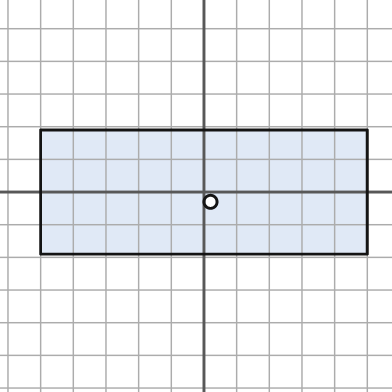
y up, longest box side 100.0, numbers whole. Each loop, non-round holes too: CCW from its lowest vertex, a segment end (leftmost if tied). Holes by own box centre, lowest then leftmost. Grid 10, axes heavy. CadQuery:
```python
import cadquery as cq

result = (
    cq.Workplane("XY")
    .moveTo(-50.0, -19.0)
    .lineTo(50.0, -19.0)
    .lineTo(50.0, 19.0)
    .lineTo(-50.0, 19.0)
    .close()
    .moveTo(2.0, -3.0)
    .circle(2.0)
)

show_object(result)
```